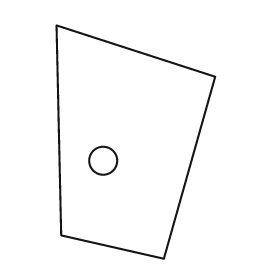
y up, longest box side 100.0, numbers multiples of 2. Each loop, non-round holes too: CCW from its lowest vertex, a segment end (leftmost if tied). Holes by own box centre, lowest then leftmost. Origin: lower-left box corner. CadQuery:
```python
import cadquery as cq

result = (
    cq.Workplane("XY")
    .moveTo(46.0, 0.0)
    .lineTo(68.0, 78.0)
    .lineTo(0.0, 100.0)
    .lineTo(2.0, 10.0)
    .close()
    .moveTo(20.0, 42.0)
    .circle(6.0)
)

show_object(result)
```